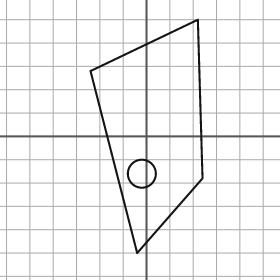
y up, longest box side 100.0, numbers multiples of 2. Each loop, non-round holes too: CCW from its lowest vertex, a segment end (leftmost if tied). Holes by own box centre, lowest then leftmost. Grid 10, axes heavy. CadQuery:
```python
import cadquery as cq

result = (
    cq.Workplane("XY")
    .moveTo(-4.0, -50.0)
    .lineTo(24.0, -18.0)
    .lineTo(22.0, 50.0)
    .lineTo(-24.0, 28.0)
    .close()
    .moveTo(-2.0, -16.0)
    .circle(6.0)
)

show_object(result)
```